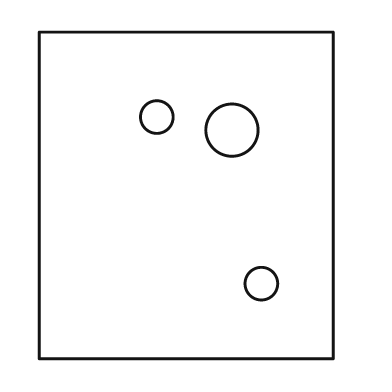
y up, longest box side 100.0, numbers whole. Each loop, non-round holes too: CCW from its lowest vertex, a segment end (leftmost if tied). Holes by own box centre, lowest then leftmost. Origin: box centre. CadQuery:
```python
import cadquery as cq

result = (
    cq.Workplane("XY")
    .moveTo(-45.0, -50.0)
    .lineTo(45.0, -50.0)
    .lineTo(45.0, 50.0)
    .lineTo(-45.0, 50.0)
    .close()
    .moveTo(23.0, -27.0)
    .circle(5.0)
    .moveTo(14.0, 20.0)
    .circle(8.0)
    .moveTo(-9.0, 24.0)
    .circle(5.0)
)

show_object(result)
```